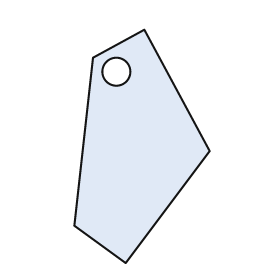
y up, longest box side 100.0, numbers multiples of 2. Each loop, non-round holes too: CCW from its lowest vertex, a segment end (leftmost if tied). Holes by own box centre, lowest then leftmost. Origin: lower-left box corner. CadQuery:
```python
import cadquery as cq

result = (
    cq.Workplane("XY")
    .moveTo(22.0, 0.0)
    .lineTo(58.0, 48.0)
    .lineTo(30.0, 100.0)
    .lineTo(8.0, 88.0)
    .lineTo(0.0, 16.0)
    .close()
    .moveTo(18.0, 82.0)
    .circle(6.0)
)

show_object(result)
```